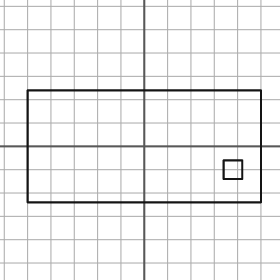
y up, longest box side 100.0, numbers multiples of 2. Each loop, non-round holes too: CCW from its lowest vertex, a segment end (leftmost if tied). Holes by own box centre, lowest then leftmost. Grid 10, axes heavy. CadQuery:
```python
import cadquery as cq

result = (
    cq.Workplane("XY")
    .moveTo(-50.0, -24.0)
    .lineTo(50.0, -24.0)
    .lineTo(50.0, 24.0)
    .lineTo(-50.0, 24.0)
    .close()
    .moveTo(34.0, -14.0)
    .lineTo(42.0, -14.0)
    .lineTo(42.0, -6.0)
    .lineTo(34.0, -6.0)
    .close()
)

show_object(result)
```